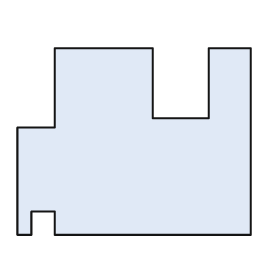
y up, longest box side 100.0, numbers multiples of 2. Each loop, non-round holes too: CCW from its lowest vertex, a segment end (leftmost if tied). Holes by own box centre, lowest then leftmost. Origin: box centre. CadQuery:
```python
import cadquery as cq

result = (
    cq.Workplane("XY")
    .moveTo(-50.0, -40.0)
    .lineTo(-44.0, -40.0)
    .lineTo(-44.0, -30.0)
    .lineTo(-34.0, -30.0)
    .lineTo(-34.0, -40.0)
    .lineTo(50.0, -40.0)
    .lineTo(50.0, 40.0)
    .lineTo(32.0, 40.0)
    .lineTo(32.0, 10.0)
    .lineTo(8.0, 10.0)
    .lineTo(8.0, 40.0)
    .lineTo(-34.0, 40.0)
    .lineTo(-34.0, 6.0)
    .lineTo(-50.0, 6.0)
    .close()
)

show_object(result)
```